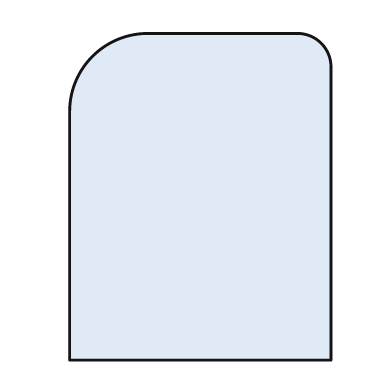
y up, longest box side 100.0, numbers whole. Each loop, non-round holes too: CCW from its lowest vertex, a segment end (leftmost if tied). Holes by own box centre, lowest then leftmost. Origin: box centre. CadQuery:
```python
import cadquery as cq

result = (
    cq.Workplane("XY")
    .moveTo(-40.0, -50.0)
    .lineTo(40.0, -50.0)
    .lineTo(40.0, 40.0)
    .threePointArc((37.0, 47.0), (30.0, 50.0))
    .lineTo(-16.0, 50.0)
    .threePointArc((-33.0, 43.0), (-40.0, 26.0))
    .close()
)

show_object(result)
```